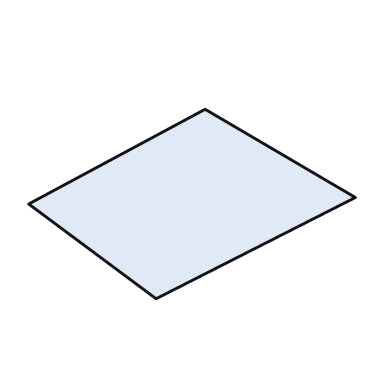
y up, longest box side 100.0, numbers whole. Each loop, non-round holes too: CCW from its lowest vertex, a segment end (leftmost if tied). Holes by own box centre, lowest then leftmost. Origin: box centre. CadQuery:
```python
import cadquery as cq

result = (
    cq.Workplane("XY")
    .moveTo(-11.0, -29.0)
    .lineTo(50.0, 2.0)
    .lineTo(4.0, 29.0)
    .lineTo(-50.0, 0.0)
    .close()
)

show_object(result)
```